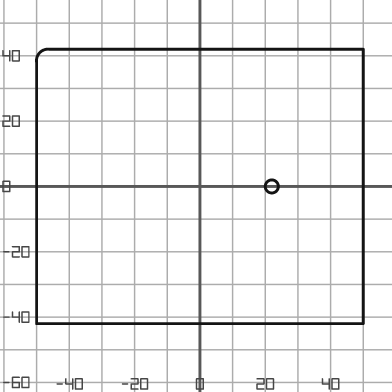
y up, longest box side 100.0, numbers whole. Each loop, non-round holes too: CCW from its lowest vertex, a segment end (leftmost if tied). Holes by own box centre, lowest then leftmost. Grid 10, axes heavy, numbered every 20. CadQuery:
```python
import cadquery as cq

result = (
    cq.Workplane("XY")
    .moveTo(-50.0, -42.0)
    .lineTo(50.0, -42.0)
    .lineTo(50.0, 42.0)
    .lineTo(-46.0, 42.0)
    .threePointArc((-49.0, 41.0), (-50.0, 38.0))
    .close()
    .moveTo(22.0, 0.0)
    .circle(2.0)
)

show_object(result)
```